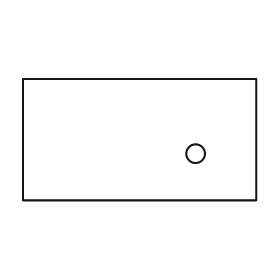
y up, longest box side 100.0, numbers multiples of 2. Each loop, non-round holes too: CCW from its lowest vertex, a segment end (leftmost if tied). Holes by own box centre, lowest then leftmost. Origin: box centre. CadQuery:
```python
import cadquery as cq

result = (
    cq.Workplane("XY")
    .moveTo(-50.0, -26.0)
    .lineTo(50.0, -26.0)
    .lineTo(50.0, 26.0)
    .lineTo(-50.0, 26.0)
    .close()
    .moveTo(24.0, -6.0)
    .circle(4.0)
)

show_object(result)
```